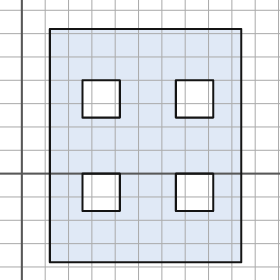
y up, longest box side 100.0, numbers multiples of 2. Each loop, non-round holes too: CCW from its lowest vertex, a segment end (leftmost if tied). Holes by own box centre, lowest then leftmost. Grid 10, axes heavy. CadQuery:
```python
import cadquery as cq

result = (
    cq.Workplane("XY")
    .moveTo(12.0, -38.0)
    .lineTo(94.0, -38.0)
    .lineTo(94.0, 62.0)
    .lineTo(12.0, 62.0)
    .close()
    .moveTo(26.0, -16.0)
    .lineTo(42.0, -16.0)
    .lineTo(42.0, 0.0)
    .lineTo(26.0, 0.0)
    .close()
    .moveTo(66.0, -16.0)
    .lineTo(82.0, -16.0)
    .lineTo(82.0, 0.0)
    .lineTo(66.0, 0.0)
    .close()
    .moveTo(26.0, 24.0)
    .lineTo(42.0, 24.0)
    .lineTo(42.0, 40.0)
    .lineTo(26.0, 40.0)
    .close()
    .moveTo(66.0, 24.0)
    .lineTo(82.0, 24.0)
    .lineTo(82.0, 40.0)
    .lineTo(66.0, 40.0)
    .close()
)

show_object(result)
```